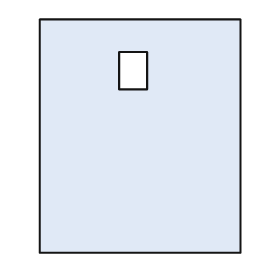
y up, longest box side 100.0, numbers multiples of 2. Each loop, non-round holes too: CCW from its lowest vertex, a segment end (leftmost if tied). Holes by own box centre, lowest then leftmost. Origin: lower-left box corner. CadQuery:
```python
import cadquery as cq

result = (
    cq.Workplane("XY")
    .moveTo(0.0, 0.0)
    .lineTo(86.0, 0.0)
    .lineTo(86.0, 100.0)
    .lineTo(0.0, 100.0)
    .close()
    .moveTo(34.0, 70.0)
    .lineTo(46.0, 70.0)
    .lineTo(46.0, 86.0)
    .lineTo(34.0, 86.0)
    .close()
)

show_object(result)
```